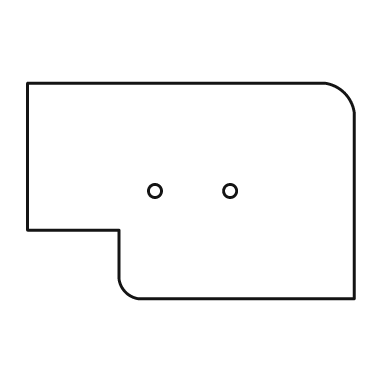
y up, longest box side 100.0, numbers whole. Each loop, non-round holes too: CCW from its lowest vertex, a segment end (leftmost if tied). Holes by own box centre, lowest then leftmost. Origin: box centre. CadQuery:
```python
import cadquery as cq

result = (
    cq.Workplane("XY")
    .moveTo(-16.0, -33.0)
    .lineTo(50.0, -33.0)
    .lineTo(50.0, 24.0)
    .threePointArc((47.0, 30.0), (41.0, 33.0))
    .lineTo(-50.0, 33.0)
    .lineTo(-50.0, -12.0)
    .lineTo(-22.0, -12.0)
    .lineTo(-22.0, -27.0)
    .threePointArc((-20.0, -31.0), (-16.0, -33.0))
    .close()
    .moveTo(-11.0, 0.0)
    .circle(2.0)
    .moveTo(12.0, 0.0)
    .circle(2.0)
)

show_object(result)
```